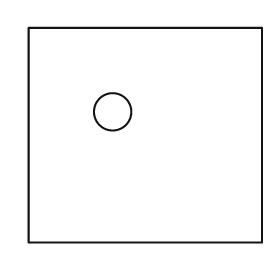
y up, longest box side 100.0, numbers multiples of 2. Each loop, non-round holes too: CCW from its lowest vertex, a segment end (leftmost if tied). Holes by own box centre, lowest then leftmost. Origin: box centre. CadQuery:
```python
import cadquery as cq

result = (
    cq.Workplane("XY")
    .moveTo(-50.0, -46.0)
    .lineTo(50.0, -46.0)
    .lineTo(50.0, 46.0)
    .lineTo(-50.0, 46.0)
    .close()
    .moveTo(-14.0, 10.0)
    .circle(8.0)
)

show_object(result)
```